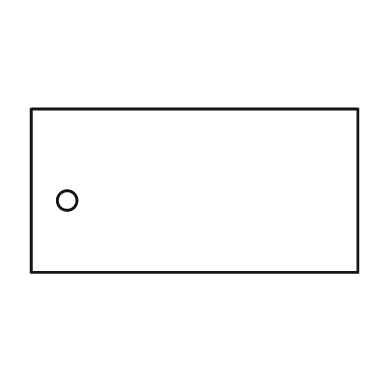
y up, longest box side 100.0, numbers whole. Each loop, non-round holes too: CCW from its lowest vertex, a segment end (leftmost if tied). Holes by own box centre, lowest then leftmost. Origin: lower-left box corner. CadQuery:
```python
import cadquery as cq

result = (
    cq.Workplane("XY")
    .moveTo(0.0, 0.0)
    .lineTo(100.0, 0.0)
    .lineTo(100.0, 50.0)
    .lineTo(0.0, 50.0)
    .close()
    .moveTo(11.0, 22.0)
    .circle(3.0)
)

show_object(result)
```